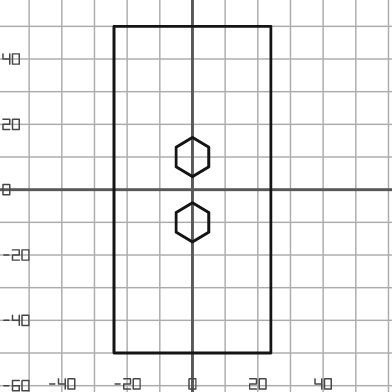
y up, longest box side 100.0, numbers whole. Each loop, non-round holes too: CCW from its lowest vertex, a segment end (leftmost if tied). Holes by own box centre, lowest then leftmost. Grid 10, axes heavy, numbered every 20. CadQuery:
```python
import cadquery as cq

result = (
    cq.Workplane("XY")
    .moveTo(-24.0, -50.0)
    .lineTo(24.0, -50.0)
    .lineTo(24.0, 50.0)
    .lineTo(-24.0, 50.0)
    .close()
    .moveTo(0.0, -16.0)
    .lineTo(5.0, -13.0)
    .lineTo(5.0, -7.0)
    .lineTo(0.0, -4.0)
    .lineTo(-5.0, -7.0)
    .lineTo(-5.0, -13.0)
    .close()
    .moveTo(0.0, 4.0)
    .lineTo(5.0, 7.0)
    .lineTo(5.0, 13.0)
    .lineTo(0.0, 16.0)
    .lineTo(-5.0, 13.0)
    .lineTo(-5.0, 7.0)
    .close()
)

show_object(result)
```